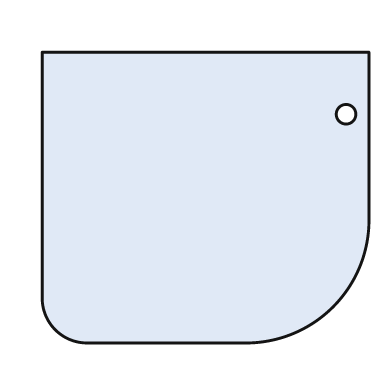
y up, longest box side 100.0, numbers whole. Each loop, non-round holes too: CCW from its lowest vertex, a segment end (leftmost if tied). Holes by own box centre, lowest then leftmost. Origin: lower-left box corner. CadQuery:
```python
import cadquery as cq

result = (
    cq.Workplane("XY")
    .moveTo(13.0, 0.0)
    .lineTo(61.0, 0.0)
    .threePointArc((89.0, 11.0), (100.0, 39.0))
    .lineTo(100.0, 89.0)
    .lineTo(0.0, 89.0)
    .lineTo(0.0, 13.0)
    .threePointArc((4.0, 4.0), (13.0, 0.0))
    .close()
    .moveTo(93.0, 70.0)
    .circle(3.0)
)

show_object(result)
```